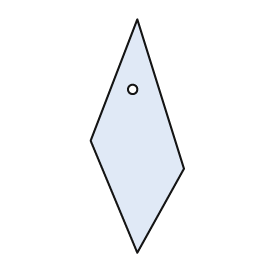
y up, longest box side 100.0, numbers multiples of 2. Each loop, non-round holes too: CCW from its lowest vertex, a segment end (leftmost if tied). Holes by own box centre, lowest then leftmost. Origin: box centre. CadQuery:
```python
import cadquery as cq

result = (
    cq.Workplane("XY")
    .moveTo(0.0, -50.0)
    .lineTo(20.0, -14.0)
    .lineTo(0.0, 50.0)
    .lineTo(-20.0, -2.0)
    .close()
    .moveTo(-2.0, 20.0)
    .circle(2.0)
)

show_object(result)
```